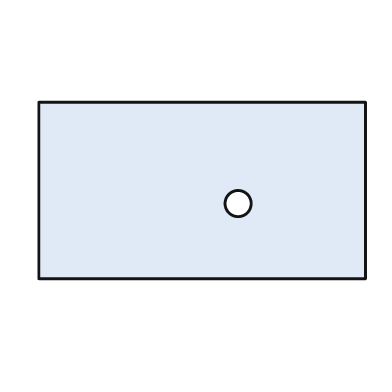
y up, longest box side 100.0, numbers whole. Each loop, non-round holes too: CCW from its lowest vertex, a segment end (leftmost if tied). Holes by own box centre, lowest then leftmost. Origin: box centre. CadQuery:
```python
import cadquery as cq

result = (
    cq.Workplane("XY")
    .moveTo(-50.0, -27.0)
    .lineTo(50.0, -27.0)
    .lineTo(50.0, 27.0)
    .lineTo(-50.0, 27.0)
    .close()
    .moveTo(11.0, -4.0)
    .circle(4.0)
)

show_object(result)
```